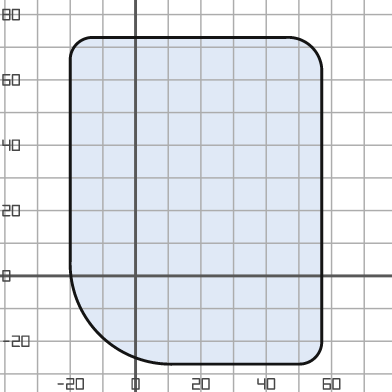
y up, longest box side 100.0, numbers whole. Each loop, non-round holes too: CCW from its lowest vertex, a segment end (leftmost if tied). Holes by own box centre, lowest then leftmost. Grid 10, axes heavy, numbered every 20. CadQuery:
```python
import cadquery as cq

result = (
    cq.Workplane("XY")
    .moveTo(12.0, -27.0)
    .lineTo(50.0, -27.0)
    .threePointArc((55.0, -25.0), (57.0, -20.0))
    .lineTo(57.0, 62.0)
    .threePointArc((54.0, 70.0), (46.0, 73.0))
    .lineTo(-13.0, 73.0)
    .threePointArc((-18.0, 71.0), (-20.0, 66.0))
    .lineTo(-20.0, 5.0)
    .threePointArc((-11.0, -18.0), (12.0, -27.0))
    .close()
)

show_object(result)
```